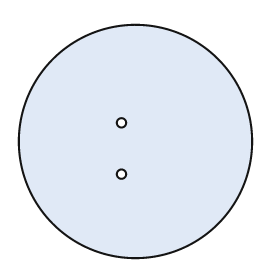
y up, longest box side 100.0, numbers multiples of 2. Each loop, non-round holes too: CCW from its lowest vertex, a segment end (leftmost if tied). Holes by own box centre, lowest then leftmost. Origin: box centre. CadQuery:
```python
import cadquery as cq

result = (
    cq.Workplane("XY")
    .moveTo(0.0, 0.0)
    .circle(50.0)
    .moveTo(-6.0, -14.0)
    .circle(2.0)
    .moveTo(-6.0, 8.0)
    .circle(2.0)
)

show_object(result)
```